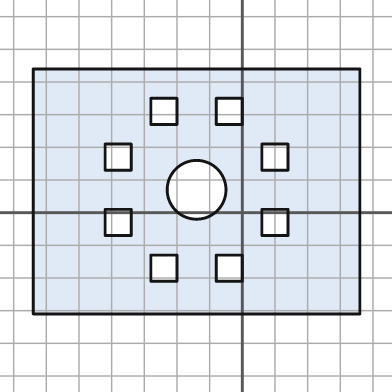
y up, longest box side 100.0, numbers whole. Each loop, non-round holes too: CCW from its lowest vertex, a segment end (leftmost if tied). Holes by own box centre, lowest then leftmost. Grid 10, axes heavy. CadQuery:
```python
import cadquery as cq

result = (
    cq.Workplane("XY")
    .moveTo(-64.0, -31.0)
    .lineTo(36.0, -31.0)
    .lineTo(36.0, 44.0)
    .lineTo(-64.0, 44.0)
    .close()
    .moveTo(-28.0, -21.0)
    .lineTo(-20.0, -21.0)
    .lineTo(-20.0, -13.0)
    .lineTo(-28.0, -13.0)
    .close()
    .moveTo(-8.0, -21.0)
    .lineTo(0.0, -21.0)
    .lineTo(0.0, -13.0)
    .lineTo(-8.0, -13.0)
    .close()
    .moveTo(-42.0, -7.0)
    .lineTo(-34.0, -7.0)
    .lineTo(-34.0, 1.0)
    .lineTo(-42.0, 1.0)
    .close()
    .moveTo(6.0, -7.0)
    .lineTo(14.0, -7.0)
    .lineTo(14.0, 1.0)
    .lineTo(6.0, 1.0)
    .close()
    .moveTo(-14.0, 7.0)
    .circle(9.0)
    .moveTo(-42.0, 13.0)
    .lineTo(-34.0, 13.0)
    .lineTo(-34.0, 21.0)
    .lineTo(-42.0, 21.0)
    .close()
    .moveTo(6.0, 13.0)
    .lineTo(14.0, 13.0)
    .lineTo(14.0, 21.0)
    .lineTo(6.0, 21.0)
    .close()
    .moveTo(-28.0, 27.0)
    .lineTo(-20.0, 27.0)
    .lineTo(-20.0, 35.0)
    .lineTo(-28.0, 35.0)
    .close()
    .moveTo(-8.0, 27.0)
    .lineTo(0.0, 27.0)
    .lineTo(0.0, 35.0)
    .lineTo(-8.0, 35.0)
    .close()
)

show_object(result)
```